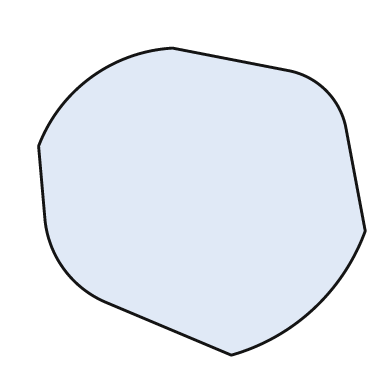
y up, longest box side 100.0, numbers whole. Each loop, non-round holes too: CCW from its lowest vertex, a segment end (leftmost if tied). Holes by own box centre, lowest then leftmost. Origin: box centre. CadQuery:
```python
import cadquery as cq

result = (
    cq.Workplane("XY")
    .moveTo(9.0, -47.0)
    .threePointArc((34.0, -33.0), (50.0, -9.0))
    .lineTo(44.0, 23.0)
    .threePointArc((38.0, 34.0), (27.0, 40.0))
    .lineTo(-9.0, 47.0)
    .threePointArc((-34.0, 38.0), (-50.0, 17.0))
    .lineTo(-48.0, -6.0)
    .threePointArc((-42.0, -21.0), (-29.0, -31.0))
    .close()
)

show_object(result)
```